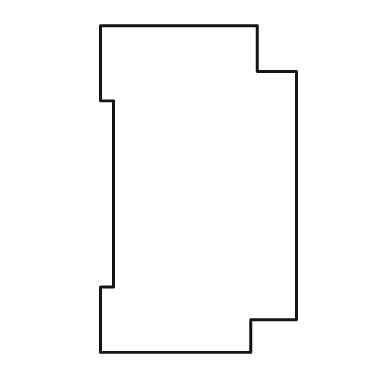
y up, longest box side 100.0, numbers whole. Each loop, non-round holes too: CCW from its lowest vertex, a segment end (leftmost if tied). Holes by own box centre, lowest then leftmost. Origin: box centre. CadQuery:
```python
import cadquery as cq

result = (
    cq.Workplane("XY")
    .moveTo(-30.0, -50.0)
    .lineTo(16.0, -50.0)
    .lineTo(16.0, -40.0)
    .lineTo(30.0, -40.0)
    .lineTo(30.0, 36.0)
    .lineTo(18.0, 36.0)
    .lineTo(18.0, 50.0)
    .lineTo(-30.0, 50.0)
    .lineTo(-30.0, 27.0)
    .lineTo(-26.0, 27.0)
    .lineTo(-26.0, -30.0)
    .lineTo(-30.0, -30.0)
    .close()
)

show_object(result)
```